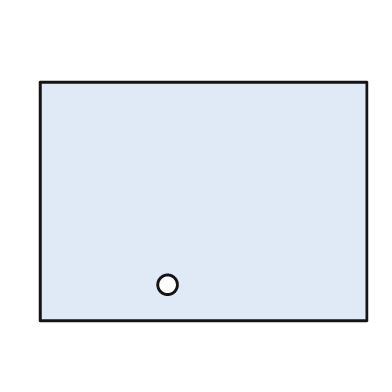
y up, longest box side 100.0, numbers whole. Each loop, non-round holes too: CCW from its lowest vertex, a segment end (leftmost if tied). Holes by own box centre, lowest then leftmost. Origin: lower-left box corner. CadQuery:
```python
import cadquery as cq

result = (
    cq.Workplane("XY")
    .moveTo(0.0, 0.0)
    .lineTo(100.0, 0.0)
    .lineTo(100.0, 73.0)
    .lineTo(0.0, 73.0)
    .close()
    .moveTo(39.0, 11.0)
    .circle(3.0)
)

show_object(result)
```